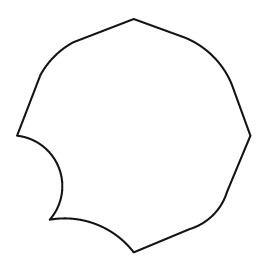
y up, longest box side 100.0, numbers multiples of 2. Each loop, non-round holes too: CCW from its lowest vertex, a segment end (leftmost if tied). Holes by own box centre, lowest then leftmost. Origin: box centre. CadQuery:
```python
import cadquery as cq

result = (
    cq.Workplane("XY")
    .moveTo(0.0, -50.0)
    .lineTo(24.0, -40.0)
    .threePointArc((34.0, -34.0), (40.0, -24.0))
    .lineTo(50.0, 0.0)
    .lineTo(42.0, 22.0)
    .threePointArc((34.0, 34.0), (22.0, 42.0))
    .lineTo(0.0, 50.0)
    .lineTo(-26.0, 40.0)
    .threePointArc((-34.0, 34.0), (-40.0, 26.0))
    .lineTo(-50.0, 0.0)
    .threePointArc((-32.0, -14.0), (-36.0, -36.0))
    .threePointArc((-16.0, -38.0), (0.0, -50.0))
    .close()
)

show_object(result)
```